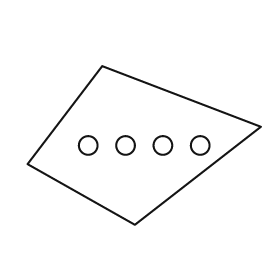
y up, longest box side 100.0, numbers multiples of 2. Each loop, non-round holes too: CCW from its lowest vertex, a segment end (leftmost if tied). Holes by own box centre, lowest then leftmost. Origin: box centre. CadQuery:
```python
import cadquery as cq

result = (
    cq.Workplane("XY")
    .moveTo(-4.0, -34.0)
    .lineTo(50.0, 8.0)
    .lineTo(-18.0, 34.0)
    .lineTo(-50.0, -8.0)
    .close()
    .moveTo(-24.0, 0.0)
    .circle(4.0)
    .moveTo(-8.0, 0.0)
    .circle(4.0)
    .moveTo(8.0, 0.0)
    .circle(4.0)
    .moveTo(24.0, 0.0)
    .circle(4.0)
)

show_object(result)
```